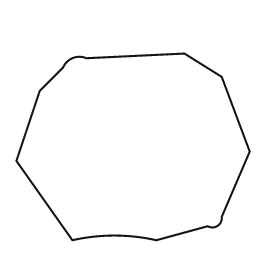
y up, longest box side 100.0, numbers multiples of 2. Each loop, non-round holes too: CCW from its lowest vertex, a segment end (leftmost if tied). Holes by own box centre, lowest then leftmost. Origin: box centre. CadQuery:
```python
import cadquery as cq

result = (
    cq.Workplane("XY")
    .moveTo(-26.0, -40.0)
    .threePointArc((-8.0, -38.0), (10.0, -40.0))
    .lineTo(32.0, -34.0)
    .threePointArc((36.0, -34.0), (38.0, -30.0))
    .lineTo(50.0, -2.0)
    .lineTo(38.0, 30.0)
    .lineTo(22.0, 40.0)
    .lineTo(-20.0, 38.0)
    .threePointArc((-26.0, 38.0), (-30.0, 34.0))
    .lineTo(-40.0, 24.0)
    .lineTo(-50.0, -6.0)
    .close()
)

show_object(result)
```